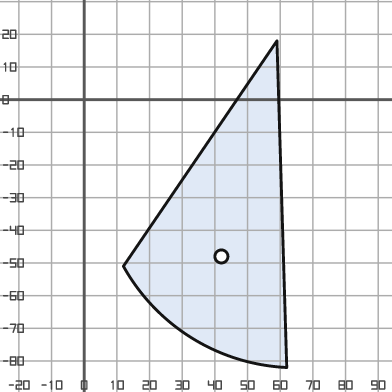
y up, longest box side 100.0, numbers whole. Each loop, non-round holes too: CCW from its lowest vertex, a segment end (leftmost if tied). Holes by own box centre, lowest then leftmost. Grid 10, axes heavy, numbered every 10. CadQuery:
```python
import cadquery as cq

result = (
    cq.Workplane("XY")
    .moveTo(62.0, -82.0)
    .lineTo(59.0, 18.0)
    .lineTo(12.0, -51.0)
    .threePointArc((33.0, -73.0), (62.0, -82.0))
    .close()
    .moveTo(42.0, -48.0)
    .circle(2.0)
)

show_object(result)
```